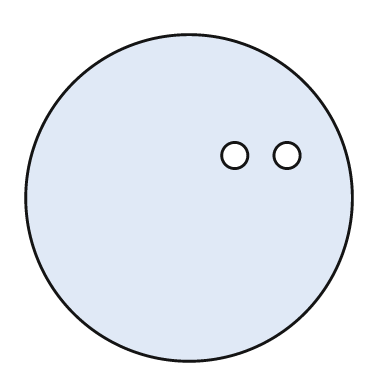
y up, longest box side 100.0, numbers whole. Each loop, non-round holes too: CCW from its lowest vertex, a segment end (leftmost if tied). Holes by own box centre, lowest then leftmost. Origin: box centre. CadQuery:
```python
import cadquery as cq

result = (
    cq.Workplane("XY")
    .moveTo(0.0, 0.0)
    .circle(50.0)
    .moveTo(14.0, 13.0)
    .circle(4.0)
    .moveTo(30.0, 13.0)
    .circle(4.0)
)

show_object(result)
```